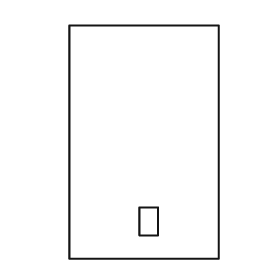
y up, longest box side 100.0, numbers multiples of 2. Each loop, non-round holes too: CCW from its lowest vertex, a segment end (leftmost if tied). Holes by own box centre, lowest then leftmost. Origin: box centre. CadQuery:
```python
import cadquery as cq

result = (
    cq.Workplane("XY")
    .moveTo(-32.0, -50.0)
    .lineTo(32.0, -50.0)
    .lineTo(32.0, 50.0)
    .lineTo(-32.0, 50.0)
    .close()
    .moveTo(-2.0, -40.0)
    .lineTo(6.0, -40.0)
    .lineTo(6.0, -28.0)
    .lineTo(-2.0, -28.0)
    .close()
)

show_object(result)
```